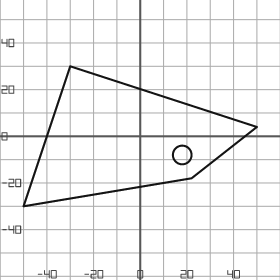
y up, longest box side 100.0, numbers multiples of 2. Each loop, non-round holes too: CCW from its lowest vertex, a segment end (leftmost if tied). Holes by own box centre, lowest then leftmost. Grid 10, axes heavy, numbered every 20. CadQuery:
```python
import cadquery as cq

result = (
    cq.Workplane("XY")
    .moveTo(-50.0, -30.0)
    .lineTo(22.0, -18.0)
    .lineTo(50.0, 4.0)
    .lineTo(-30.0, 30.0)
    .close()
    .moveTo(18.0, -8.0)
    .circle(4.0)
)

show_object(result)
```